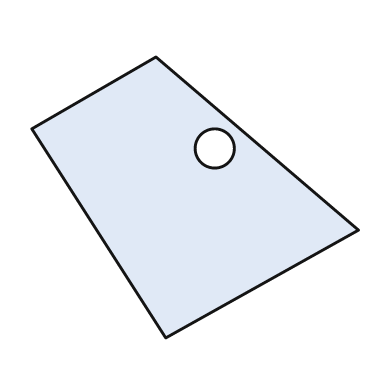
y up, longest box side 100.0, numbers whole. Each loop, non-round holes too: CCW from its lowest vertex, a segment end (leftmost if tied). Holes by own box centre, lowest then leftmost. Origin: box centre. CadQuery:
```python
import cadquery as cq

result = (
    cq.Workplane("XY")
    .moveTo(-9.0, -43.0)
    .lineTo(50.0, -10.0)
    .lineTo(-12.0, 43.0)
    .lineTo(-50.0, 21.0)
    .close()
    .moveTo(6.0, 15.0)
    .circle(6.0)
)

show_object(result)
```